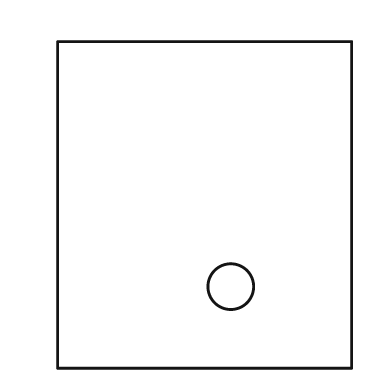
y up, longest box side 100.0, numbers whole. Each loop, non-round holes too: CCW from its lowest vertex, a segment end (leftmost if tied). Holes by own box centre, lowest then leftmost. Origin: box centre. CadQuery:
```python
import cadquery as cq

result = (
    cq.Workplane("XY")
    .moveTo(-45.0, -50.0)
    .lineTo(45.0, -50.0)
    .lineTo(45.0, 50.0)
    .lineTo(-45.0, 50.0)
    .close()
    .moveTo(8.0, -25.0)
    .circle(7.0)
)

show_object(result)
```